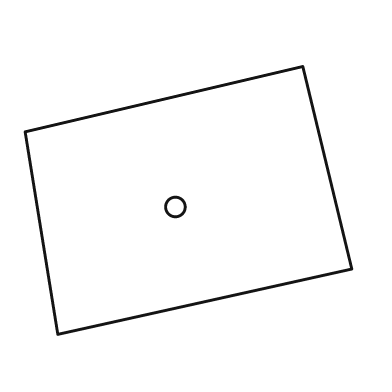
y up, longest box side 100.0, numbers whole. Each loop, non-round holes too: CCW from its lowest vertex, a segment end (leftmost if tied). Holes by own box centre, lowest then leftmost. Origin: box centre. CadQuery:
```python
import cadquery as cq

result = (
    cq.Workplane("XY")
    .moveTo(-40.0, -41.0)
    .lineTo(50.0, -21.0)
    .lineTo(35.0, 41.0)
    .lineTo(-50.0, 21.0)
    .close()
    .moveTo(-4.0, -2.0)
    .circle(3.0)
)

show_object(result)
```